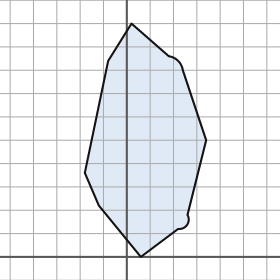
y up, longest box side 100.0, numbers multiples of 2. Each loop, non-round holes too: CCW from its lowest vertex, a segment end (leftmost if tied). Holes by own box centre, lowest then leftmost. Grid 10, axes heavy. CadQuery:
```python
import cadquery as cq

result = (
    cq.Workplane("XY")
    .moveTo(6.0, 0.0)
    .lineTo(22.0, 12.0)
    .threePointArc((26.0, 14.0), (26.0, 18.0))
    .lineTo(34.0, 50.0)
    .lineTo(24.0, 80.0)
    .threePointArc((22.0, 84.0), (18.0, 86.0))
    .lineTo(2.0, 100.0)
    .lineTo(-8.0, 84.0)
    .lineTo(-18.0, 36.0)
    .lineTo(-12.0, 22.0)
    .close()
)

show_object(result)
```